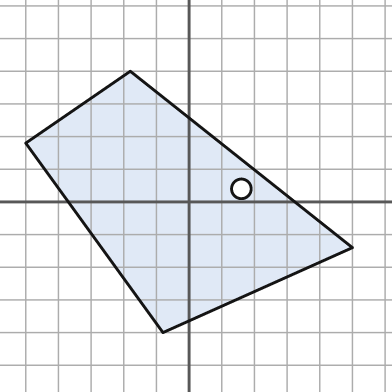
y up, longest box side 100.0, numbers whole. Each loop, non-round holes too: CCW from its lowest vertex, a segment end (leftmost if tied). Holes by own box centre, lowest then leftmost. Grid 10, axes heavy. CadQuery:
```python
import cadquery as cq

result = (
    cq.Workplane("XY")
    .moveTo(-8.0, -40.0)
    .lineTo(50.0, -14.0)
    .lineTo(-18.0, 40.0)
    .lineTo(-50.0, 18.0)
    .close()
    .moveTo(16.0, 4.0)
    .circle(3.0)
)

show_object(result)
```